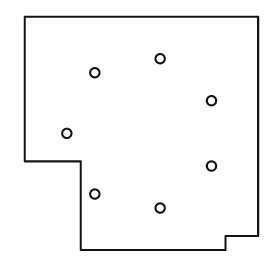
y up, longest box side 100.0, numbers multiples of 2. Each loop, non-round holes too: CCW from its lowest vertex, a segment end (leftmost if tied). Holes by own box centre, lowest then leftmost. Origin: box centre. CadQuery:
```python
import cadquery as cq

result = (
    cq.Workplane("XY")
    .moveTo(-26.0, -50.0)
    .lineTo(36.0, -50.0)
    .lineTo(36.0, -44.0)
    .lineTo(50.0, -44.0)
    .lineTo(50.0, 50.0)
    .lineTo(-50.0, 50.0)
    .lineTo(-50.0, -12.0)
    .lineTo(-26.0, -12.0)
    .close()
    .moveTo(8.0, -32.0)
    .circle(2.0)
    .moveTo(-20.0, -26.0)
    .circle(2.0)
    .moveTo(30.0, -14.0)
    .circle(2.0)
    .moveTo(-32.0, 0.0)
    .circle(2.0)
    .moveTo(30.0, 14.0)
    .circle(2.0)
    .moveTo(-20.0, 26.0)
    .circle(2.0)
    .moveTo(8.0, 32.0)
    .circle(2.0)
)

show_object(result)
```